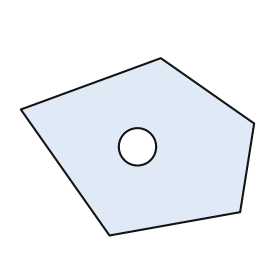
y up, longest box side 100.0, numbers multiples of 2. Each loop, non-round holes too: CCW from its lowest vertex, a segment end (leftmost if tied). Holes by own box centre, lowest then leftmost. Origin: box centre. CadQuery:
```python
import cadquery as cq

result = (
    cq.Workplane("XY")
    .moveTo(-12.0, -38.0)
    .lineTo(44.0, -28.0)
    .lineTo(50.0, 10.0)
    .lineTo(10.0, 38.0)
    .lineTo(-50.0, 16.0)
    .close()
    .moveTo(0.0, 0.0)
    .circle(8.0)
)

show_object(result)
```